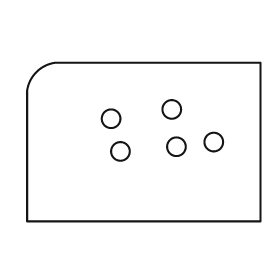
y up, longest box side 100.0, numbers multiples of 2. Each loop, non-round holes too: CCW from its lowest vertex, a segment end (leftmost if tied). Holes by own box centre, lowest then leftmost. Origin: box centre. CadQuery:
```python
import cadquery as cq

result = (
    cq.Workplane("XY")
    .moveTo(-50.0, -34.0)
    .lineTo(50.0, -34.0)
    .lineTo(50.0, 34.0)
    .lineTo(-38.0, 34.0)
    .threePointArc((-46.0, 30.0), (-50.0, 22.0))
    .close()
    .moveTo(-10.0, -4.0)
    .circle(4.0)
    .moveTo(14.0, -2.0)
    .circle(4.0)
    .moveTo(30.0, 0.0)
    .circle(4.0)
    .moveTo(-14.0, 10.0)
    .circle(4.0)
    .moveTo(12.0, 14.0)
    .circle(4.0)
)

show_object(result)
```